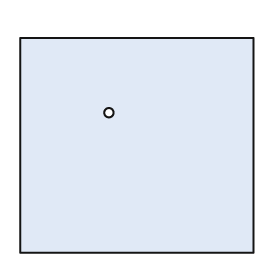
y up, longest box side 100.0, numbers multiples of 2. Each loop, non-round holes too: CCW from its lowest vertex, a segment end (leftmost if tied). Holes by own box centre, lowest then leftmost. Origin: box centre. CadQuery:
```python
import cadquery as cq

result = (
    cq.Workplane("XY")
    .moveTo(-50.0, -46.0)
    .lineTo(50.0, -46.0)
    .lineTo(50.0, 46.0)
    .lineTo(-50.0, 46.0)
    .close()
    .moveTo(-12.0, 14.0)
    .circle(2.0)
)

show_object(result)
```